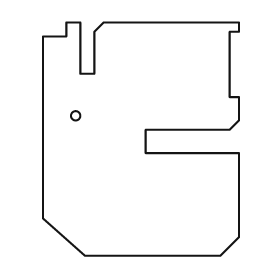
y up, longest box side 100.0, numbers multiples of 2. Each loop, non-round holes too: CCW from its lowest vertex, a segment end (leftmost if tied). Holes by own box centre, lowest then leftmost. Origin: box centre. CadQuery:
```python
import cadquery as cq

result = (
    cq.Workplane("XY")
    .moveTo(-24.0, -50.0)
    .lineTo(34.0, -50.0)
    .lineTo(42.0, -42.0)
    .lineTo(42.0, -6.0)
    .lineTo(2.0, -6.0)
    .lineTo(2.0, 4.0)
    .lineTo(38.0, 4.0)
    .lineTo(42.0, 8.0)
    .lineTo(42.0, 18.0)
    .lineTo(38.0, 18.0)
    .lineTo(38.0, 46.0)
    .lineTo(42.0, 46.0)
    .lineTo(42.0, 50.0)
    .lineTo(-16.0, 50.0)
    .lineTo(-20.0, 46.0)
    .lineTo(-20.0, 28.0)
    .lineTo(-26.0, 28.0)
    .lineTo(-26.0, 50.0)
    .lineTo(-32.0, 50.0)
    .lineTo(-32.0, 44.0)
    .lineTo(-42.0, 44.0)
    .lineTo(-42.0, -34.0)
    .close()
    .moveTo(-28.0, 10.0)
    .circle(2.0)
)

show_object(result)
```